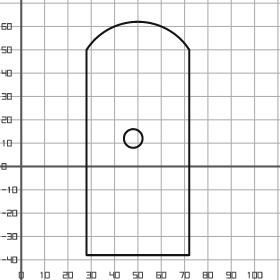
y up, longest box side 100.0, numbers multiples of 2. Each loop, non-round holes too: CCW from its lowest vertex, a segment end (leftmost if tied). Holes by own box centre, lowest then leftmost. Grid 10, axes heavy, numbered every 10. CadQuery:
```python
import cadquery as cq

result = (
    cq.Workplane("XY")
    .moveTo(28.0, -38.0)
    .lineTo(72.0, -38.0)
    .lineTo(72.0, 50.0)
    .threePointArc((50.0, 62.0), (28.0, 50.0))
    .close()
    .moveTo(48.0, 12.0)
    .circle(4.0)
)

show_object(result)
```